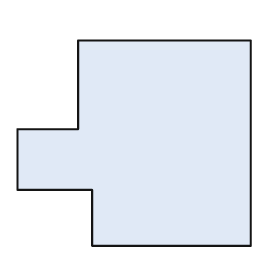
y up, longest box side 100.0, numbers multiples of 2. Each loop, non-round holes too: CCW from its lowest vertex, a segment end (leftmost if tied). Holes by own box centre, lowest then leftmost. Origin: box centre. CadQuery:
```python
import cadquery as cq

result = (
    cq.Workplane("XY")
    .moveTo(-18.0, -44.0)
    .lineTo(50.0, -44.0)
    .lineTo(50.0, 44.0)
    .lineTo(-24.0, 44.0)
    .lineTo(-24.0, 6.0)
    .lineTo(-50.0, 6.0)
    .lineTo(-50.0, -20.0)
    .lineTo(-18.0, -20.0)
    .close()
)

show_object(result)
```